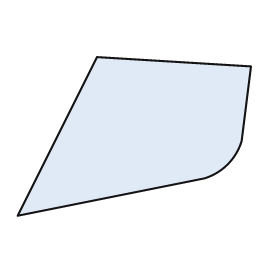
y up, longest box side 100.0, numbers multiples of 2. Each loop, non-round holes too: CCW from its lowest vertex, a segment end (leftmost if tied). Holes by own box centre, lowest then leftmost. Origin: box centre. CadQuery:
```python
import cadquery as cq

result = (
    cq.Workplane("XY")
    .moveTo(-50.0, -34.0)
    .lineTo(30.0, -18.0)
    .threePointArc((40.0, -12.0), (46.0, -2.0))
    .lineTo(50.0, 30.0)
    .lineTo(-16.0, 34.0)
    .close()
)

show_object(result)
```